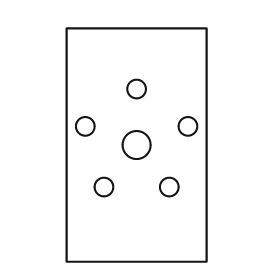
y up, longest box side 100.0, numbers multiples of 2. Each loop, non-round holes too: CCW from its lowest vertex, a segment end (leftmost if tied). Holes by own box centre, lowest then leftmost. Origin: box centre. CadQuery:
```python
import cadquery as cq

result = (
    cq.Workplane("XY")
    .moveTo(-30.0, -50.0)
    .lineTo(30.0, -50.0)
    .lineTo(30.0, 50.0)
    .lineTo(-30.0, 50.0)
    .close()
    .moveTo(-14.0, -18.0)
    .circle(4.0)
    .moveTo(14.0, -18.0)
    .circle(4.0)
    .moveTo(0.0, 0.0)
    .circle(6.0)
    .moveTo(-22.0, 8.0)
    .circle(4.0)
    .moveTo(22.0, 8.0)
    .circle(4.0)
    .moveTo(0.0, 24.0)
    .circle(4.0)
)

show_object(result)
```